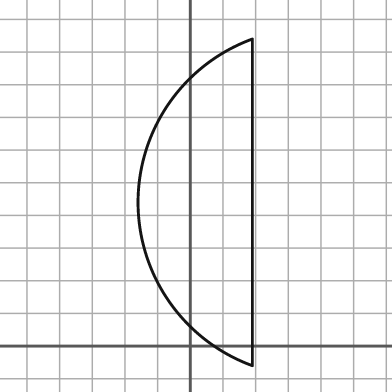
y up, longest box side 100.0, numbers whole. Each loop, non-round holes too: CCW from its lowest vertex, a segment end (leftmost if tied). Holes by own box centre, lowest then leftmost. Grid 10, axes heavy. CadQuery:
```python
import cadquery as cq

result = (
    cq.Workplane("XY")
    .moveTo(19.0, -6.0)
    .lineTo(19.0, 94.0)
    .threePointArc((-16.0, 44.0), (19.0, -6.0))
    .close()
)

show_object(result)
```